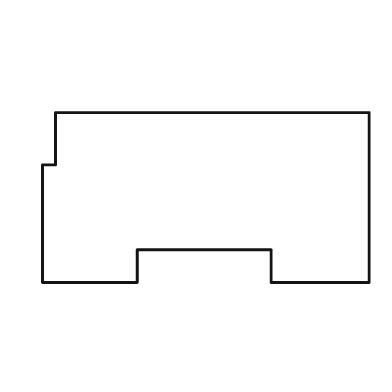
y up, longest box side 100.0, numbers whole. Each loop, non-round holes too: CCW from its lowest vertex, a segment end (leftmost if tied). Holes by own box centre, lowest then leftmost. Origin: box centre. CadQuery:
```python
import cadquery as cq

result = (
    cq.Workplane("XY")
    .moveTo(-50.0, -26.0)
    .lineTo(-21.0, -26.0)
    .lineTo(-21.0, -16.0)
    .lineTo(20.0, -16.0)
    .lineTo(20.0, -26.0)
    .lineTo(50.0, -26.0)
    .lineTo(50.0, 26.0)
    .lineTo(-46.0, 26.0)
    .lineTo(-46.0, 10.0)
    .lineTo(-50.0, 10.0)
    .close()
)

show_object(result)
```